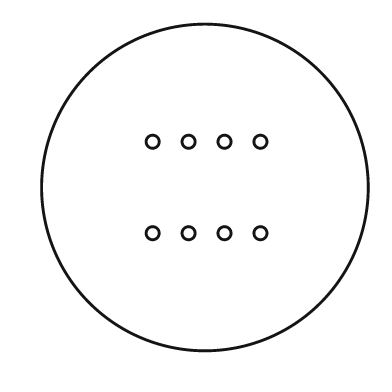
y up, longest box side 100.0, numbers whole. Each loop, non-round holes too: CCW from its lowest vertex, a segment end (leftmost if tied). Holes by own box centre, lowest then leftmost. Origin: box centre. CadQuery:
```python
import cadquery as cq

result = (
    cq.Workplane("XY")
    .moveTo(0.0, 0.0)
    .circle(50.0)
    .moveTo(-16.0, -14.0)
    .circle(2.0)
    .moveTo(-5.0, -14.0)
    .circle(2.0)
    .moveTo(6.0, -14.0)
    .circle(2.0)
    .moveTo(17.0, -14.0)
    .circle(2.0)
    .moveTo(-16.0, 14.0)
    .circle(2.0)
    .moveTo(-5.0, 14.0)
    .circle(2.0)
    .moveTo(6.0, 14.0)
    .circle(2.0)
    .moveTo(17.0, 14.0)
    .circle(2.0)
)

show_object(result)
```